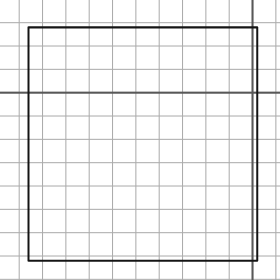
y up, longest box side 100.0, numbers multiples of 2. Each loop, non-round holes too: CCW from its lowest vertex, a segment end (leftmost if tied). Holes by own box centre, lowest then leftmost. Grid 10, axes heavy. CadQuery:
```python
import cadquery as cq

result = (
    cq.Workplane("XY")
    .moveTo(-96.0, -72.0)
    .lineTo(2.0, -72.0)
    .lineTo(2.0, 28.0)
    .lineTo(-96.0, 28.0)
    .close()
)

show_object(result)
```